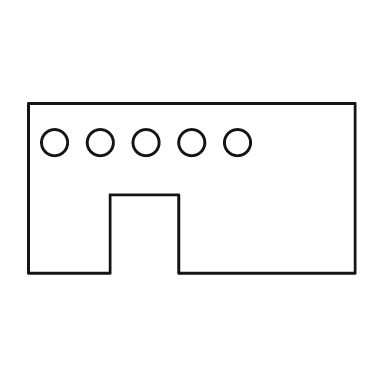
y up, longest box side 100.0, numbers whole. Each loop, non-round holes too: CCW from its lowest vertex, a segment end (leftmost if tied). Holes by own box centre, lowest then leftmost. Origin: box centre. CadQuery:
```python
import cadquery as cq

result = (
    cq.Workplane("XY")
    .moveTo(-50.0, -26.0)
    .lineTo(-25.0, -26.0)
    .lineTo(-25.0, -2.0)
    .lineTo(-4.0, -2.0)
    .lineTo(-4.0, -26.0)
    .lineTo(50.0, -26.0)
    .lineTo(50.0, 26.0)
    .lineTo(-50.0, 26.0)
    .close()
    .moveTo(-42.0, 14.0)
    .circle(4.0)
    .moveTo(-28.0, 14.0)
    .circle(4.0)
    .moveTo(-14.0, 14.0)
    .circle(4.0)
    .moveTo(0.0, 14.0)
    .circle(4.0)
    .moveTo(14.0, 14.0)
    .circle(4.0)
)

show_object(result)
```